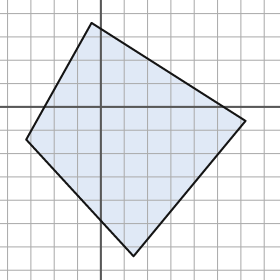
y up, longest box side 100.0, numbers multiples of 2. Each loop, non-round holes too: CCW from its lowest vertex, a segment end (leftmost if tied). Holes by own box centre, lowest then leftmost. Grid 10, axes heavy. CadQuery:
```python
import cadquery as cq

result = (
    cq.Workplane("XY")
    .moveTo(14.0, -64.0)
    .lineTo(62.0, -6.0)
    .lineTo(-4.0, 36.0)
    .lineTo(-32.0, -14.0)
    .close()
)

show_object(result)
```